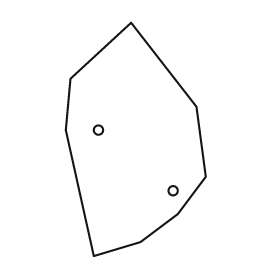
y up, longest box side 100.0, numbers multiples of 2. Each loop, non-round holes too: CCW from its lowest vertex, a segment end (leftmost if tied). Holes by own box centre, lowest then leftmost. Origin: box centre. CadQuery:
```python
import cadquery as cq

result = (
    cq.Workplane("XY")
    .moveTo(-18.0, -50.0)
    .lineTo(2.0, -44.0)
    .lineTo(18.0, -32.0)
    .lineTo(30.0, -16.0)
    .lineTo(26.0, 14.0)
    .lineTo(-2.0, 50.0)
    .lineTo(-28.0, 26.0)
    .lineTo(-30.0, 4.0)
    .close()
    .moveTo(16.0, -22.0)
    .circle(2.0)
    .moveTo(-16.0, 4.0)
    .circle(2.0)
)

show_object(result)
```